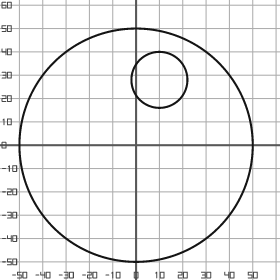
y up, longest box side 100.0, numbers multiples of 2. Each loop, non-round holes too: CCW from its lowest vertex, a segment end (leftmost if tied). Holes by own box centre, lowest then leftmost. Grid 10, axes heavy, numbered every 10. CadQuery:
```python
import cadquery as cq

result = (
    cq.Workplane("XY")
    .moveTo(0.0, 0.0)
    .circle(50.0)
    .moveTo(10.0, 28.0)
    .circle(12.0)
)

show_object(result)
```